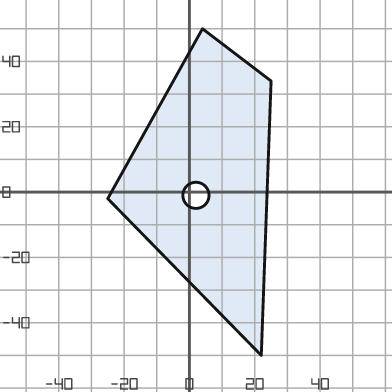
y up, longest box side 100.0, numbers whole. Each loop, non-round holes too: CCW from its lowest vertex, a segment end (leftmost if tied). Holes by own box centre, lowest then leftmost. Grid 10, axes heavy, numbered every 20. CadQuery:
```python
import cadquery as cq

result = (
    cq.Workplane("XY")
    .moveTo(22.0, -50.0)
    .lineTo(25.0, 34.0)
    .lineTo(4.0, 50.0)
    .lineTo(-25.0, -2.0)
    .close()
    .moveTo(2.0, -1.0)
    .circle(4.0)
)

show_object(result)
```